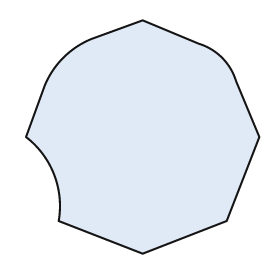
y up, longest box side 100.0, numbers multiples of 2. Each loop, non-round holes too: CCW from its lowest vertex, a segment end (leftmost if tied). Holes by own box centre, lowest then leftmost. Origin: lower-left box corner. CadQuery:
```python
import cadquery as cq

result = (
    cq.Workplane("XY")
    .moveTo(50.0, 0.0)
    .lineTo(86.0, 14.0)
    .lineTo(100.0, 50.0)
    .lineTo(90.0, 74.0)
    .threePointArc((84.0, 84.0), (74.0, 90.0))
    .lineTo(50.0, 100.0)
    .lineTo(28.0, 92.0)
    .threePointArc((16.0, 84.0), (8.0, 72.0))
    .lineTo(0.0, 50.0)
    .threePointArc((12.0, 34.0), (14.0, 14.0))
    .close()
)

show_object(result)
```